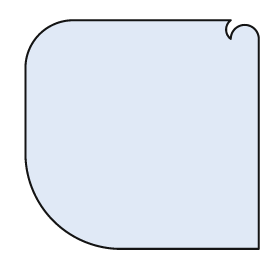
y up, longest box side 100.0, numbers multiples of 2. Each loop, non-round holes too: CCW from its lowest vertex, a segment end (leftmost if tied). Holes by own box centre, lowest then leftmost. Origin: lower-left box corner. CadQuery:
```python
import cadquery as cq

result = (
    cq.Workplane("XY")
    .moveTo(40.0, 0.0)
    .lineTo(100.0, 0.0)
    .lineTo(100.0, 90.0)
    .threePointArc((94.0, 96.0), (88.0, 90.0))
    .threePointArc((86.0, 94.0), (88.0, 98.0))
    .lineTo(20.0, 98.0)
    .threePointArc((6.0, 92.0), (0.0, 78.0))
    .lineTo(0.0, 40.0)
    .threePointArc((12.0, 12.0), (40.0, 0.0))
    .close()
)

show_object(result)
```